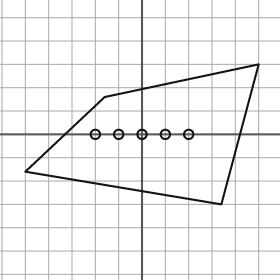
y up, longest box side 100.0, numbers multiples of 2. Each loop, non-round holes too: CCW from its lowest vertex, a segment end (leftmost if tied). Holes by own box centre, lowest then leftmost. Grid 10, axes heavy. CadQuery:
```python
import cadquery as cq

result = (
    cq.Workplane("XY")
    .moveTo(34.0, -30.0)
    .lineTo(50.0, 30.0)
    .lineTo(-16.0, 16.0)
    .lineTo(-50.0, -16.0)
    .close()
    .moveTo(-20.0, 0.0)
    .circle(2.0)
    .moveTo(-10.0, 0.0)
    .circle(2.0)
    .moveTo(0.0, 0.0)
    .circle(2.0)
    .moveTo(10.0, 0.0)
    .circle(2.0)
    .moveTo(20.0, 0.0)
    .circle(2.0)
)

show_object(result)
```